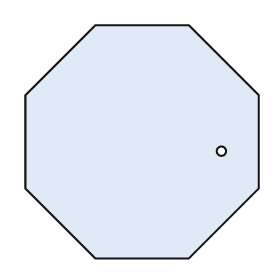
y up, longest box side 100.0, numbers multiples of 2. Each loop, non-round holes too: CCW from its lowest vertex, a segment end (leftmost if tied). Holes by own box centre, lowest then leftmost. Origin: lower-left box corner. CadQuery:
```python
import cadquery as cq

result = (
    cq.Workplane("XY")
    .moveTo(30.0, 0.0)
    .lineTo(70.0, 0.0)
    .lineTo(100.0, 30.0)
    .lineTo(100.0, 70.0)
    .lineTo(70.0, 100.0)
    .lineTo(30.0, 100.0)
    .lineTo(0.0, 70.0)
    .lineTo(0.0, 30.0)
    .close()
    .moveTo(84.0, 46.0)
    .circle(2.0)
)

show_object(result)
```